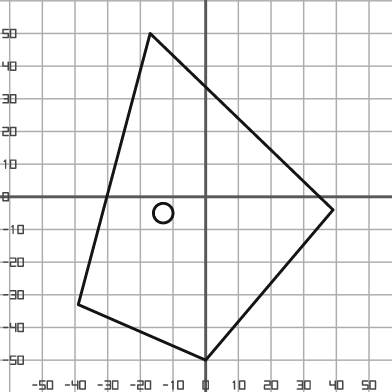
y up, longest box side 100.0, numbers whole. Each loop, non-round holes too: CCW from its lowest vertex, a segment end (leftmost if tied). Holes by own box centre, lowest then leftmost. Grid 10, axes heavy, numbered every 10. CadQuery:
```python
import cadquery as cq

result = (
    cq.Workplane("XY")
    .moveTo(0.0, -50.0)
    .lineTo(39.0, -4.0)
    .lineTo(-17.0, 50.0)
    .lineTo(-39.0, -33.0)
    .close()
    .moveTo(-13.0, -5.0)
    .circle(3.0)
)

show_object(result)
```